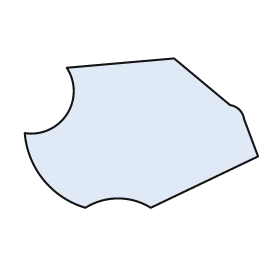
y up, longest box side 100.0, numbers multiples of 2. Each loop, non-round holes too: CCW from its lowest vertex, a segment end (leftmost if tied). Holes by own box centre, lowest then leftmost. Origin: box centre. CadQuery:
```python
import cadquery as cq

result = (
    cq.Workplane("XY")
    .moveTo(-24.0, -32.0)
    .threePointArc((-10.0, -28.0), (4.0, -32.0))
    .lineTo(50.0, -10.0)
    .lineTo(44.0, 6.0)
    .threePointArc((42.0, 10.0), (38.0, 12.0))
    .lineTo(14.0, 32.0)
    .lineTo(-32.0, 28.0)
    .threePointArc((-32.0, 8.0), (-50.0, 0.0))
    .threePointArc((-42.0, -20.0), (-24.0, -32.0))
    .close()
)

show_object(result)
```